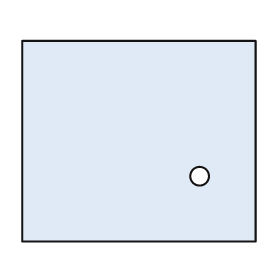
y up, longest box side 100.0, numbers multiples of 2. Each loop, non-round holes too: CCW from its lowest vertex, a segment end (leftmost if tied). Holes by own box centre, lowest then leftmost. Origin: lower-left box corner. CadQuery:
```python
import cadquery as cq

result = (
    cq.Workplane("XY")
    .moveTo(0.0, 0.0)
    .lineTo(100.0, 0.0)
    .lineTo(100.0, 86.0)
    .lineTo(0.0, 86.0)
    .close()
    .moveTo(76.0, 28.0)
    .circle(4.0)
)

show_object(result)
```